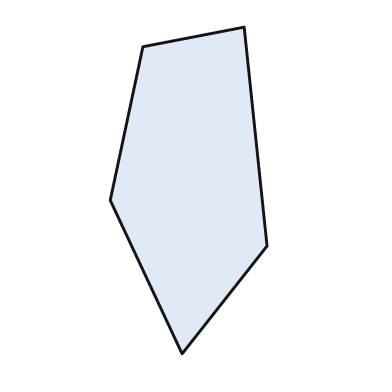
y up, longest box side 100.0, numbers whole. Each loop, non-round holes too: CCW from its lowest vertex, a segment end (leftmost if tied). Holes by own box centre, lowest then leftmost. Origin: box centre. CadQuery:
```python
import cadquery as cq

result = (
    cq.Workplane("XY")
    .moveTo(-2.0, -50.0)
    .lineTo(24.0, -17.0)
    .lineTo(17.0, 50.0)
    .lineTo(-14.0, 44.0)
    .lineTo(-24.0, -3.0)
    .close()
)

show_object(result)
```